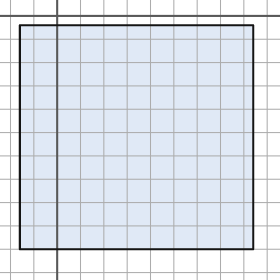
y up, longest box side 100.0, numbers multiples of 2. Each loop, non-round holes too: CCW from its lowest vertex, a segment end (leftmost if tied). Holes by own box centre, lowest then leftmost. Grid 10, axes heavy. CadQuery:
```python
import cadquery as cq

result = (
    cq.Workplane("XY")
    .moveTo(-16.0, -100.0)
    .lineTo(84.0, -100.0)
    .lineTo(84.0, -4.0)
    .lineTo(-16.0, -4.0)
    .close()
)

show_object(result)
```